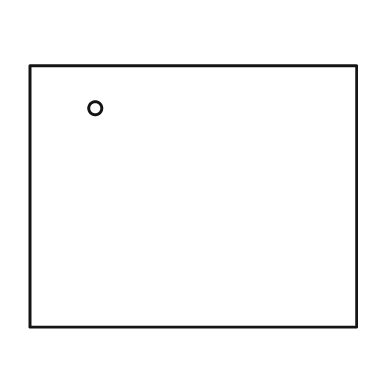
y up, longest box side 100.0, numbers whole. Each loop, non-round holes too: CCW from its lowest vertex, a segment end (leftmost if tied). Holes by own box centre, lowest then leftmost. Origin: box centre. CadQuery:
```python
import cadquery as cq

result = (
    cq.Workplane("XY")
    .moveTo(-50.0, -40.0)
    .lineTo(50.0, -40.0)
    .lineTo(50.0, 40.0)
    .lineTo(-50.0, 40.0)
    .close()
    .moveTo(-30.0, 27.0)
    .circle(2.0)
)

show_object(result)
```